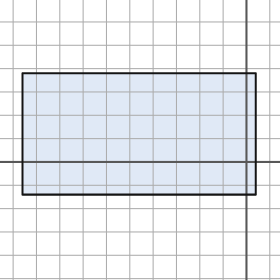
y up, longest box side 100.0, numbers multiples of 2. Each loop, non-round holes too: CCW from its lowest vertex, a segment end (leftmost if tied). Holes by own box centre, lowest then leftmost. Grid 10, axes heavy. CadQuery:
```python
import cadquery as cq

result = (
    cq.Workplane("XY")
    .moveTo(-96.0, -14.0)
    .lineTo(4.0, -14.0)
    .lineTo(4.0, 38.0)
    .lineTo(-96.0, 38.0)
    .close()
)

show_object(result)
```